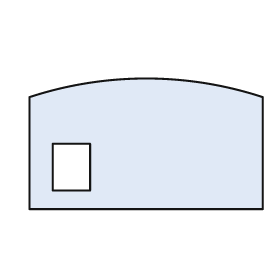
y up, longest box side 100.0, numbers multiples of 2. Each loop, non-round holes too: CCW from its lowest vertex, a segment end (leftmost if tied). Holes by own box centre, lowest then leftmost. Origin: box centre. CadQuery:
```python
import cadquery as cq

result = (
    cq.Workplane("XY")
    .moveTo(-50.0, -28.0)
    .lineTo(50.0, -28.0)
    .lineTo(50.0, 20.0)
    .threePointArc((0.0, 28.0), (-50.0, 20.0))
    .close()
    .moveTo(-40.0, -20.0)
    .lineTo(-24.0, -20.0)
    .lineTo(-24.0, 0.0)
    .lineTo(-40.0, 0.0)
    .close()
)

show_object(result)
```